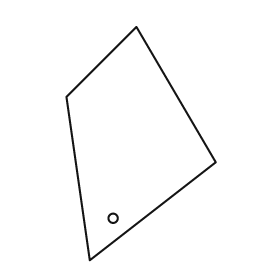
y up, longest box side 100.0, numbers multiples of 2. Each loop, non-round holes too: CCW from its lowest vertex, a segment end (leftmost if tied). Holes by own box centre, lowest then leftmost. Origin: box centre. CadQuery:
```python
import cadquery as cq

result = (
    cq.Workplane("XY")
    .moveTo(-22.0, -50.0)
    .lineTo(32.0, -8.0)
    .lineTo(-2.0, 50.0)
    .lineTo(-32.0, 20.0)
    .close()
    .moveTo(-12.0, -32.0)
    .circle(2.0)
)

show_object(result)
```